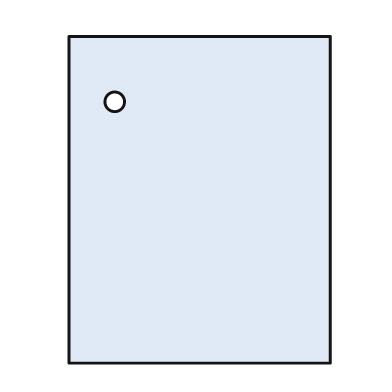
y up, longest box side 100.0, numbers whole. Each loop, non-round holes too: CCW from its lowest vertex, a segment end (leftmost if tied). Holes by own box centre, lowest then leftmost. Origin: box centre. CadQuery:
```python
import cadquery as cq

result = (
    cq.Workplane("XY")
    .moveTo(-40.0, -50.0)
    .lineTo(40.0, -50.0)
    .lineTo(40.0, 50.0)
    .lineTo(-40.0, 50.0)
    .close()
    .moveTo(-26.0, 30.0)
    .circle(3.0)
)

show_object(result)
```